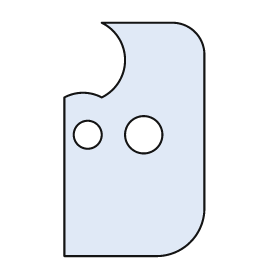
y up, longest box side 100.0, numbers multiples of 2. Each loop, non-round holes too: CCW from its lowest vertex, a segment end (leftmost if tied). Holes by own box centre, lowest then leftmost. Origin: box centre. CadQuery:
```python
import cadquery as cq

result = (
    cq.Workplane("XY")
    .moveTo(-30.0, -50.0)
    .lineTo(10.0, -50.0)
    .threePointArc((24.0, -44.0), (30.0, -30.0))
    .lineTo(30.0, 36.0)
    .threePointArc((26.0, 46.0), (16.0, 50.0))
    .lineTo(-14.0, 50.0)
    .threePointArc((-4.0, 34.0), (-14.0, 18.0))
    .threePointArc((-22.0, 20.0), (-30.0, 18.0))
    .close()
    .moveTo(-20.0, 2.0)
    .circle(6.0)
    .moveTo(4.0, 2.0)
    .circle(8.0)
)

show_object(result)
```